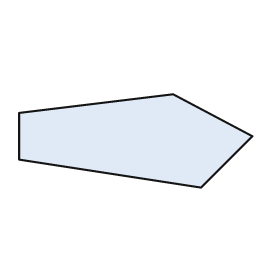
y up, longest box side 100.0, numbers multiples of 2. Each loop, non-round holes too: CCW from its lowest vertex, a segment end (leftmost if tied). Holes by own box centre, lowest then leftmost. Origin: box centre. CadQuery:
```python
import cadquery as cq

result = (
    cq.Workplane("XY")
    .moveTo(28.0, -20.0)
    .lineTo(50.0, 2.0)
    .lineTo(16.0, 20.0)
    .lineTo(-50.0, 12.0)
    .lineTo(-50.0, -8.0)
    .close()
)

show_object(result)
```